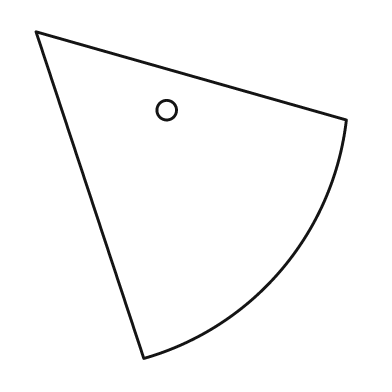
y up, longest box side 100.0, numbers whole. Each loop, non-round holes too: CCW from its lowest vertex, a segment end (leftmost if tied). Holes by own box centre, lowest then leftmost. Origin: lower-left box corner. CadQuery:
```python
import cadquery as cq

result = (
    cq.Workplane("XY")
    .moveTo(33.0, 0.0)
    .threePointArc((75.0, 27.0), (95.0, 73.0))
    .lineTo(0.0, 100.0)
    .close()
    .moveTo(40.0, 76.0)
    .circle(3.0)
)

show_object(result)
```